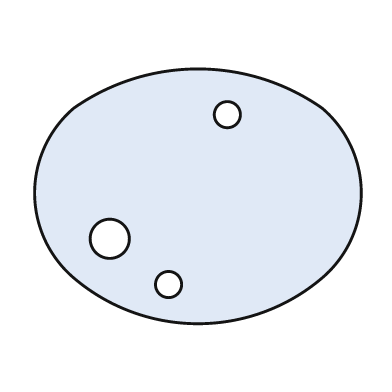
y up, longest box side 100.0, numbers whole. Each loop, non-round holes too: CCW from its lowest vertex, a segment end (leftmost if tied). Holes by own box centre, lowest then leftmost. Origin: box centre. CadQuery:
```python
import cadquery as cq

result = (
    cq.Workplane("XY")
    .moveTo(-38.0, -25.0)
    .threePointArc((0.0, -39.0), (38.0, -25.0))
    .threePointArc((50.0, 1.0), (38.0, 27.0))
    .threePointArc((0.0, 39.0), (-38.0, 27.0))
    .threePointArc((-50.0, 1.0), (-38.0, -25.0))
    .close()
    .moveTo(-9.0, -27.0)
    .circle(4.0)
    .moveTo(-27.0, -13.0)
    .circle(6.0)
    .moveTo(9.0, 25.0)
    .circle(4.0)
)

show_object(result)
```